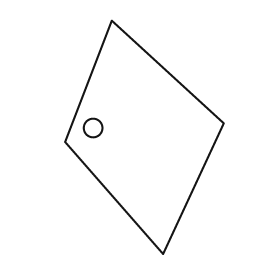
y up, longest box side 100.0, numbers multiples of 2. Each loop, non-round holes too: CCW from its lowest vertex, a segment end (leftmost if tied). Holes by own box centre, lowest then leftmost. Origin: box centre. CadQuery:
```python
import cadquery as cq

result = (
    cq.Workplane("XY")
    .moveTo(8.0, -50.0)
    .lineTo(34.0, 6.0)
    .lineTo(-14.0, 50.0)
    .lineTo(-34.0, -2.0)
    .close()
    .moveTo(-22.0, 4.0)
    .circle(4.0)
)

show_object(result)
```